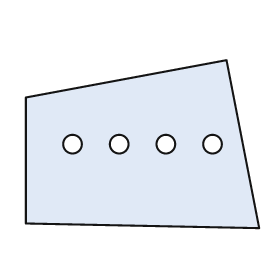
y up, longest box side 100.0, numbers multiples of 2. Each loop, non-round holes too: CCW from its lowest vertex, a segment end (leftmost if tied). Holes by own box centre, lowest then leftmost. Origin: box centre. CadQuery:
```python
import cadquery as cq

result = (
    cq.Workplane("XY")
    .moveTo(50.0, -36.0)
    .lineTo(36.0, 36.0)
    .lineTo(-50.0, 20.0)
    .lineTo(-50.0, -34.0)
    .close()
    .moveTo(-30.0, 0.0)
    .circle(4.0)
    .moveTo(-10.0, 0.0)
    .circle(4.0)
    .moveTo(10.0, 0.0)
    .circle(4.0)
    .moveTo(30.0, 0.0)
    .circle(4.0)
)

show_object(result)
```